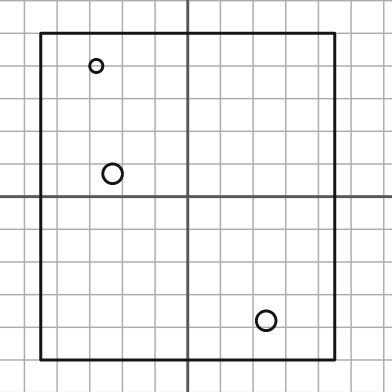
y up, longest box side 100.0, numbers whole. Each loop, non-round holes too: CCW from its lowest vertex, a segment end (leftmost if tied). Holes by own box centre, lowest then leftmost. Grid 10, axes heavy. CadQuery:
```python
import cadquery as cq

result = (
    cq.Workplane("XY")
    .moveTo(-45.0, -50.0)
    .lineTo(45.0, -50.0)
    .lineTo(45.0, 50.0)
    .lineTo(-45.0, 50.0)
    .close()
    .moveTo(24.0, -38.0)
    .circle(3.0)
    .moveTo(-23.0, 7.0)
    .circle(3.0)
    .moveTo(-28.0, 40.0)
    .circle(2.0)
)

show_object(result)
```